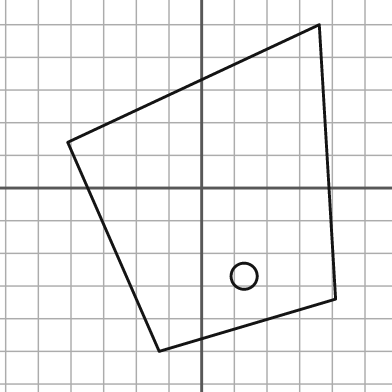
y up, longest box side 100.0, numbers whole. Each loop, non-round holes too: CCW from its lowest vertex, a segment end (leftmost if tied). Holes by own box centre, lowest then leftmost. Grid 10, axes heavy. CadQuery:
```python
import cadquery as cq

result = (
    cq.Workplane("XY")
    .moveTo(-13.0, -50.0)
    .lineTo(41.0, -34.0)
    .lineTo(36.0, 50.0)
    .lineTo(-41.0, 14.0)
    .close()
    .moveTo(13.0, -27.0)
    .circle(4.0)
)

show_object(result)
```